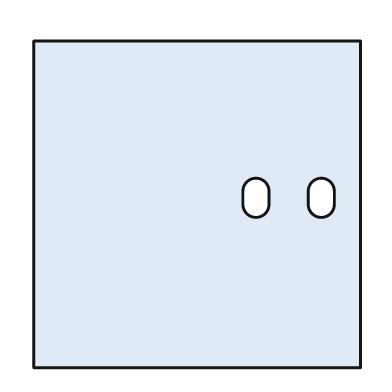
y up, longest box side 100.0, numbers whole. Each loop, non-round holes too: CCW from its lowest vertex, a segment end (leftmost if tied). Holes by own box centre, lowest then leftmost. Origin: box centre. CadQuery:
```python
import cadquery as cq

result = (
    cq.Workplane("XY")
    .moveTo(-50.0, -50.0)
    .lineTo(50.0, -50.0)
    .lineTo(50.0, 50.0)
    .lineTo(-50.0, 50.0)
    .close()
    .moveTo(14.0, 0.0)
    .threePointArc((18.0, -4.0), (22.0, 0.0))
    .lineTo(22.0, 4.0)
    .threePointArc((18.0, 8.0), (14.0, 4.0))
    .close()
    .moveTo(34.0, 0.0)
    .threePointArc((38.0, -4.0), (42.0, 0.0))
    .lineTo(42.0, 4.0)
    .threePointArc((38.0, 8.0), (34.0, 4.0))
    .close()
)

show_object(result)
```